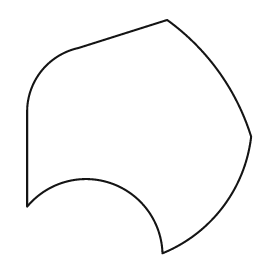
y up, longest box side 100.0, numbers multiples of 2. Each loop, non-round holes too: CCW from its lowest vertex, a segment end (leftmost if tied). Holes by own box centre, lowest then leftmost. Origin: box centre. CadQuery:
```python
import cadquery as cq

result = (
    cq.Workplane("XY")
    .moveTo(10.0, -50.0)
    .threePointArc((36.0, -30.0), (48.0, 0.0))
    .threePointArc((34.0, 28.0), (12.0, 50.0))
    .lineTo(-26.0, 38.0)
    .threePointArc((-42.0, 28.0), (-48.0, 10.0))
    .lineTo(-48.0, -30.0)
    .threePointArc((-12.0, -20.0), (10.0, -50.0))
    .close()
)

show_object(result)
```